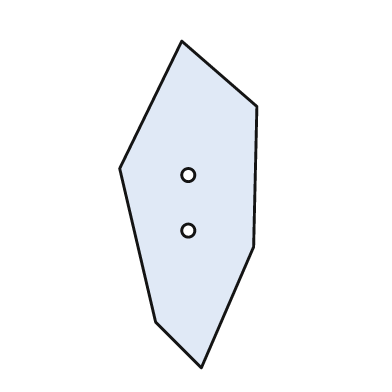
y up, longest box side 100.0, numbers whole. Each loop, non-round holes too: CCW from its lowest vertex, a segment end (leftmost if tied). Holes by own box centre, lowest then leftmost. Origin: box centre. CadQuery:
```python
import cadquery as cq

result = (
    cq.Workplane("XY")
    .moveTo(4.0, -50.0)
    .lineTo(20.0, -13.0)
    .lineTo(21.0, 30.0)
    .lineTo(-2.0, 50.0)
    .lineTo(-21.0, 11.0)
    .lineTo(-10.0, -36.0)
    .close()
    .moveTo(0.0, -8.0)
    .circle(2.0)
    .moveTo(0.0, 9.0)
    .circle(2.0)
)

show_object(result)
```